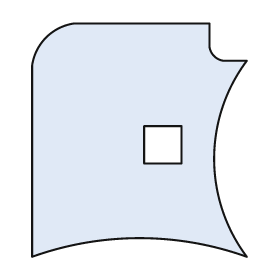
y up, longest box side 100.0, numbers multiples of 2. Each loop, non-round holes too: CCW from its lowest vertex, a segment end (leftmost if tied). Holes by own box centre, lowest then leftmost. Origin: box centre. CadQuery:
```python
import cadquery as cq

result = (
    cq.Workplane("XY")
    .moveTo(-46.0, -50.0)
    .threePointArc((0.0, -42.0), (46.0, -50.0))
    .threePointArc((32.0, -8.0), (46.0, 34.0))
    .lineTo(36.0, 34.0)
    .threePointArc((32.0, 36.0), (30.0, 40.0))
    .lineTo(30.0, 50.0)
    .lineTo(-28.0, 50.0)
    .threePointArc((-40.0, 44.0), (-46.0, 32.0))
    .close()
    .moveTo(2.0, -10.0)
    .lineTo(18.0, -10.0)
    .lineTo(18.0, 6.0)
    .lineTo(2.0, 6.0)
    .close()
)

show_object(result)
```